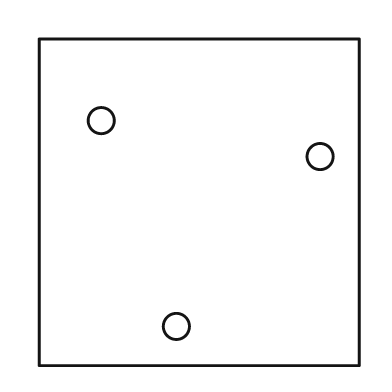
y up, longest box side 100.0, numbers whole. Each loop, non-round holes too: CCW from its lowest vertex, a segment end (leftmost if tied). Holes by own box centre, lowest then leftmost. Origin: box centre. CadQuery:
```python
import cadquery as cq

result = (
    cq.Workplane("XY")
    .moveTo(-49.0, -50.0)
    .lineTo(49.0, -50.0)
    .lineTo(49.0, 50.0)
    .lineTo(-49.0, 50.0)
    .close()
    .moveTo(-7.0, -38.0)
    .circle(4.0)
    .moveTo(37.0, 14.0)
    .circle(4.0)
    .moveTo(-30.0, 25.0)
    .circle(4.0)
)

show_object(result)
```